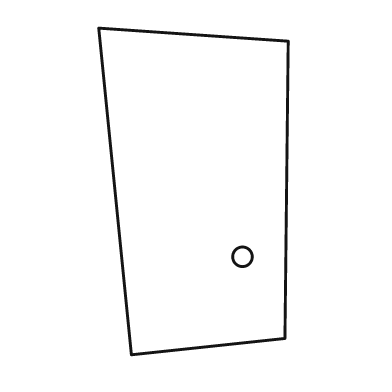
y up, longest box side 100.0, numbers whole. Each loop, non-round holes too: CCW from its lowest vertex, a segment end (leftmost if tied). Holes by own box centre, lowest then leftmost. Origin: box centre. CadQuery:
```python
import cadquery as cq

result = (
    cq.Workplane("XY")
    .moveTo(-19.0, -50.0)
    .lineTo(28.0, -45.0)
    .lineTo(29.0, 46.0)
    .lineTo(-29.0, 50.0)
    .close()
    .moveTo(15.0, -20.0)
    .circle(3.0)
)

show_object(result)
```